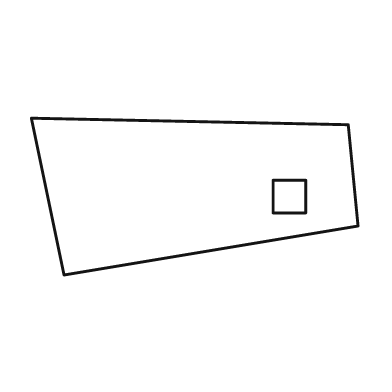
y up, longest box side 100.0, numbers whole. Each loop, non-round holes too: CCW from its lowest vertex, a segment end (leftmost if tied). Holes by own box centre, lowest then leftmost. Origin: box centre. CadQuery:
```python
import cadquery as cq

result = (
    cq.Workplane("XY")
    .moveTo(-40.0, -24.0)
    .lineTo(50.0, -9.0)
    .lineTo(47.0, 22.0)
    .lineTo(-50.0, 24.0)
    .close()
    .moveTo(24.0, -5.0)
    .lineTo(34.0, -5.0)
    .lineTo(34.0, 5.0)
    .lineTo(24.0, 5.0)
    .close()
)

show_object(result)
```